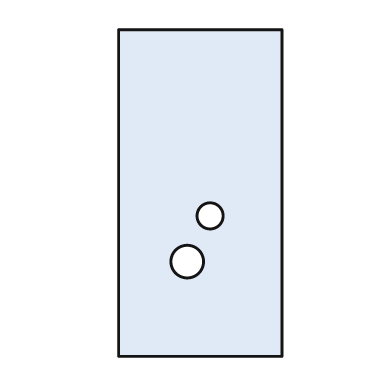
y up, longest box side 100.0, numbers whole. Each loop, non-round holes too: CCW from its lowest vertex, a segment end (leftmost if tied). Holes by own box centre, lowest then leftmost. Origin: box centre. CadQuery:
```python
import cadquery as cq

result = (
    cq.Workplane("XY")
    .moveTo(-25.0, -50.0)
    .lineTo(25.0, -50.0)
    .lineTo(25.0, 50.0)
    .lineTo(-25.0, 50.0)
    .close()
    .moveTo(-4.0, -21.0)
    .circle(5.0)
    .moveTo(3.0, -7.0)
    .circle(4.0)
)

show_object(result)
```